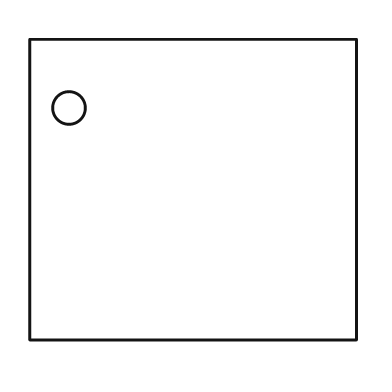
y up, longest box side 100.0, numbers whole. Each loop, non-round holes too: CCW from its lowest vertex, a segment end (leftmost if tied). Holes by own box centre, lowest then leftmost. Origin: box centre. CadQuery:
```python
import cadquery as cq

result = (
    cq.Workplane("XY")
    .moveTo(-50.0, -46.0)
    .lineTo(50.0, -46.0)
    .lineTo(50.0, 46.0)
    .lineTo(-50.0, 46.0)
    .close()
    .moveTo(-38.0, 25.0)
    .circle(5.0)
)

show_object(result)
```